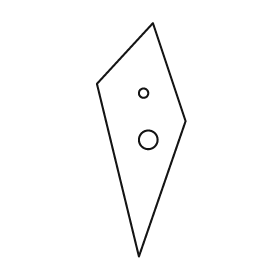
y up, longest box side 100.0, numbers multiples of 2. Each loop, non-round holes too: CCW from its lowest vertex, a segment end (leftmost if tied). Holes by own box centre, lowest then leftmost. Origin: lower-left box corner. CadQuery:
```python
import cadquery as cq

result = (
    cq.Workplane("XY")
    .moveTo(18.0, 0.0)
    .lineTo(38.0, 58.0)
    .lineTo(24.0, 100.0)
    .lineTo(0.0, 74.0)
    .close()
    .moveTo(22.0, 50.0)
    .circle(4.0)
    .moveTo(20.0, 70.0)
    .circle(2.0)
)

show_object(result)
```